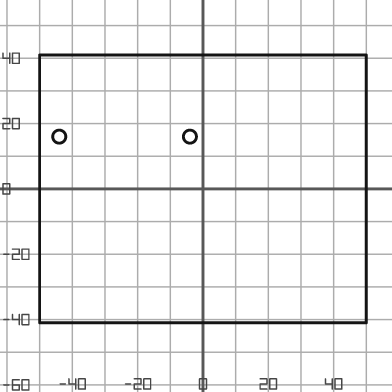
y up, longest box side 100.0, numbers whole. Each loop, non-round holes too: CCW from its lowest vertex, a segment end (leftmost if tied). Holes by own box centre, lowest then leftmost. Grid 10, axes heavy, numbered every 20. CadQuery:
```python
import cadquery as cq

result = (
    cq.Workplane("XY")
    .moveTo(-50.0, -41.0)
    .lineTo(50.0, -41.0)
    .lineTo(50.0, 41.0)
    .lineTo(-50.0, 41.0)
    .close()
    .moveTo(-44.0, 16.0)
    .circle(2.0)
    .moveTo(-4.0, 16.0)
    .circle(2.0)
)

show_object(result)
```